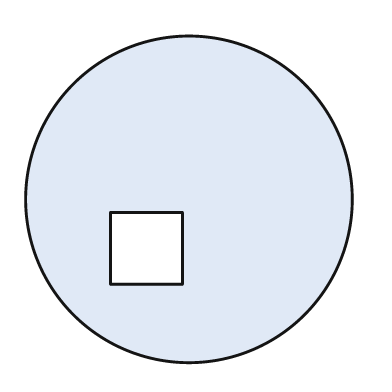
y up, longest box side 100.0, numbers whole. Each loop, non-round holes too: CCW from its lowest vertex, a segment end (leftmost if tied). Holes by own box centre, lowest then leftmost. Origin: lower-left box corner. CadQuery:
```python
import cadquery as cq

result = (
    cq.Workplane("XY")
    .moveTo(50.0, 50.0)
    .circle(50.0)
    .moveTo(26.0, 24.0)
    .lineTo(48.0, 24.0)
    .lineTo(48.0, 46.0)
    .lineTo(26.0, 46.0)
    .close()
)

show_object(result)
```